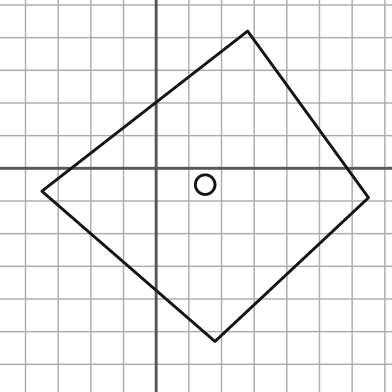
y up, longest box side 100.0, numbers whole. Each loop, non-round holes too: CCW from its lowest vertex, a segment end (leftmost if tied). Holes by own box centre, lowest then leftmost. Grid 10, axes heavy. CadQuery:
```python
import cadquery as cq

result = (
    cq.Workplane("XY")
    .moveTo(18.0, -53.0)
    .lineTo(65.0, -9.0)
    .lineTo(28.0, 42.0)
    .lineTo(-35.0, -7.0)
    .close()
    .moveTo(15.0, -5.0)
    .circle(3.0)
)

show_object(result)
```